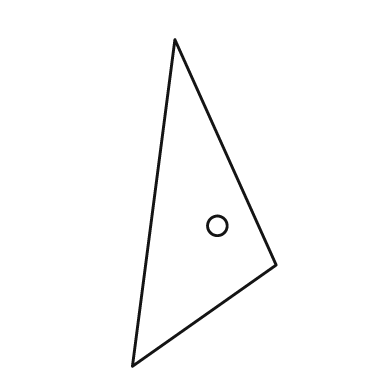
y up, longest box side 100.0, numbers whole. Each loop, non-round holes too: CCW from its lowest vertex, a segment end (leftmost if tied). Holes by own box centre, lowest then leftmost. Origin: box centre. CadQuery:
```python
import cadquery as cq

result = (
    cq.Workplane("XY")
    .moveTo(-22.0, -50.0)
    .lineTo(22.0, -19.0)
    .lineTo(-9.0, 50.0)
    .close()
    .moveTo(4.0, -7.0)
    .circle(3.0)
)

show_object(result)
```